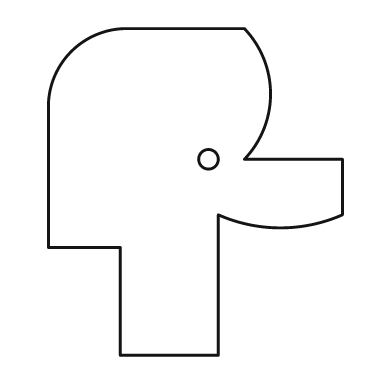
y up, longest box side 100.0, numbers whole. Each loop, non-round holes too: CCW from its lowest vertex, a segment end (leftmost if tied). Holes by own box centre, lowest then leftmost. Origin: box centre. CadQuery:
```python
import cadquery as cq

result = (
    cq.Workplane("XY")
    .moveTo(-23.0, -50.0)
    .lineTo(7.0, -50.0)
    .lineTo(7.0, -7.0)
    .threePointArc((26.0, -11.0), (45.0, -7.0))
    .lineTo(45.0, 10.0)
    .lineTo(15.0, 10.0)
    .threePointArc((23.0, 30.0), (15.0, 50.0))
    .lineTo(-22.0, 50.0)
    .threePointArc((-38.0, 43.0), (-45.0, 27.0))
    .lineTo(-45.0, -17.0)
    .lineTo(-23.0, -17.0)
    .close()
    .moveTo(4.0, 10.0)
    .circle(3.0)
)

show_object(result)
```